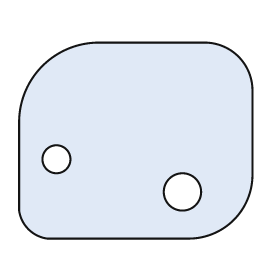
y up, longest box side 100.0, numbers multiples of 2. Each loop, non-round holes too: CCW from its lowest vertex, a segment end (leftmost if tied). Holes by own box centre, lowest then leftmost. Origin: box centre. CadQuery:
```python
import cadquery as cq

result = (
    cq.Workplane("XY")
    .moveTo(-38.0, -42.0)
    .lineTo(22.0, -42.0)
    .threePointArc((42.0, -34.0), (50.0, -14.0))
    .lineTo(50.0, 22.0)
    .threePointArc((44.0, 36.0), (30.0, 42.0))
    .lineTo(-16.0, 42.0)
    .threePointArc((-40.0, 32.0), (-50.0, 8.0))
    .lineTo(-50.0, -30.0)
    .threePointArc((-46.0, -38.0), (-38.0, -42.0))
    .close()
    .moveTo(20.0, -22.0)
    .circle(8.0)
    .moveTo(-34.0, -8.0)
    .circle(6.0)
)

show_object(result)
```